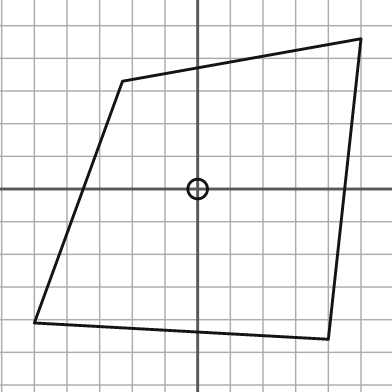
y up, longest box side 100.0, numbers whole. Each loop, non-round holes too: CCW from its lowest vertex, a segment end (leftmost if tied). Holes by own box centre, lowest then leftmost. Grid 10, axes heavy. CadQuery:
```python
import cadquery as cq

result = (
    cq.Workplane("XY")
    .moveTo(40.0, -46.0)
    .lineTo(50.0, 46.0)
    .lineTo(-23.0, 33.0)
    .lineTo(-50.0, -41.0)
    .close()
    .moveTo(0.0, 0.0)
    .circle(3.0)
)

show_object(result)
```